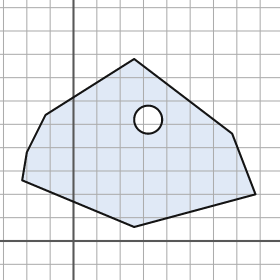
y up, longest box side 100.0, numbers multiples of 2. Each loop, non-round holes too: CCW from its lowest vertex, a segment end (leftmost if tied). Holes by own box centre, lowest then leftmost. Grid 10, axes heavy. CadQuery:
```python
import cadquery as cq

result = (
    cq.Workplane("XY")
    .moveTo(26.0, 6.0)
    .lineTo(78.0, 20.0)
    .lineTo(68.0, 46.0)
    .lineTo(26.0, 78.0)
    .lineTo(-12.0, 54.0)
    .lineTo(-20.0, 38.0)
    .lineTo(-22.0, 26.0)
    .close()
    .moveTo(32.0, 52.0)
    .circle(6.0)
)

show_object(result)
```